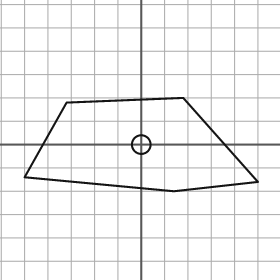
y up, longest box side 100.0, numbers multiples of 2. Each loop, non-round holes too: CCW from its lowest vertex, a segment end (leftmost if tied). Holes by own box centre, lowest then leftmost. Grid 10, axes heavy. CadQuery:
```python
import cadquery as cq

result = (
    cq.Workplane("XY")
    .moveTo(14.0, -20.0)
    .lineTo(50.0, -16.0)
    .lineTo(18.0, 20.0)
    .lineTo(-32.0, 18.0)
    .lineTo(-50.0, -14.0)
    .close()
    .moveTo(0.0, 0.0)
    .circle(4.0)
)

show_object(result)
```